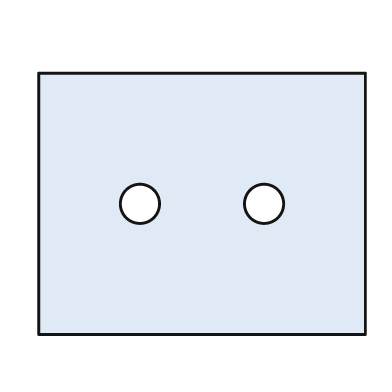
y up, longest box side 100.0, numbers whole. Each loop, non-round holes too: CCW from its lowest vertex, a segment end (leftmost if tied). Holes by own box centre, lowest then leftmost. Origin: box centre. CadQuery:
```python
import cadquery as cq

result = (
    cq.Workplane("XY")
    .moveTo(-50.0, -40.0)
    .lineTo(50.0, -40.0)
    .lineTo(50.0, 40.0)
    .lineTo(-50.0, 40.0)
    .close()
    .moveTo(-19.0, 0.0)
    .circle(6.0)
    .moveTo(19.0, 0.0)
    .circle(6.0)
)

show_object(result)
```